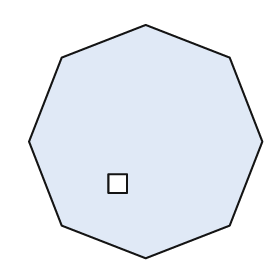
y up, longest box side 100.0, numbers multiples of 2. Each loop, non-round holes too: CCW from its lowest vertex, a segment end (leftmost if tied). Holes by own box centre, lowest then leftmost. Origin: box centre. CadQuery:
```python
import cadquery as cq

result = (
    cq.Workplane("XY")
    .moveTo(0.0, -50.0)
    .lineTo(36.0, -36.0)
    .lineTo(50.0, 0.0)
    .lineTo(36.0, 36.0)
    .lineTo(0.0, 50.0)
    .lineTo(-36.0, 36.0)
    .lineTo(-50.0, 0.0)
    .lineTo(-36.0, -36.0)
    .close()
    .moveTo(-16.0, -22.0)
    .lineTo(-8.0, -22.0)
    .lineTo(-8.0, -14.0)
    .lineTo(-16.0, -14.0)
    .close()
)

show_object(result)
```